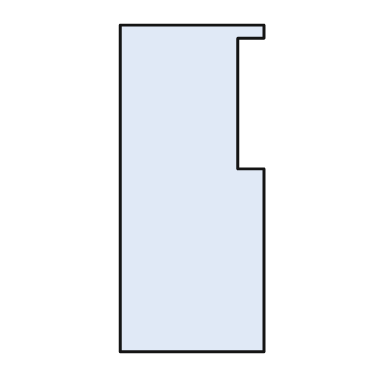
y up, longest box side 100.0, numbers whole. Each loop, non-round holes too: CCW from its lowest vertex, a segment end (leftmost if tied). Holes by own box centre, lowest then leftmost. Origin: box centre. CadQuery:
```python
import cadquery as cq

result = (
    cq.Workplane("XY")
    .moveTo(-22.0, -50.0)
    .lineTo(22.0, -50.0)
    .lineTo(22.0, 6.0)
    .lineTo(14.0, 6.0)
    .lineTo(14.0, 46.0)
    .lineTo(22.0, 46.0)
    .lineTo(22.0, 50.0)
    .lineTo(-22.0, 50.0)
    .close()
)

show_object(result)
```